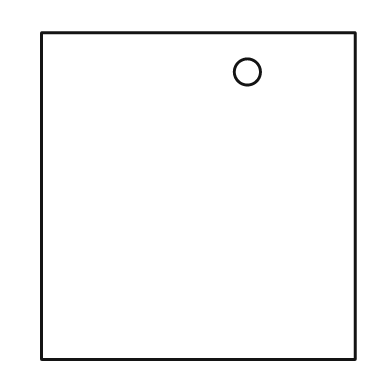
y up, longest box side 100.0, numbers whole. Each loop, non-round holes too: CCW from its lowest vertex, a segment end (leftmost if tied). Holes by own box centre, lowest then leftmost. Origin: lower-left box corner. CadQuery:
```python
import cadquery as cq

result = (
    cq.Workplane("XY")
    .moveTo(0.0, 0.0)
    .lineTo(96.0, 0.0)
    .lineTo(96.0, 100.0)
    .lineTo(0.0, 100.0)
    .close()
    .moveTo(63.0, 88.0)
    .circle(4.0)
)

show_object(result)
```